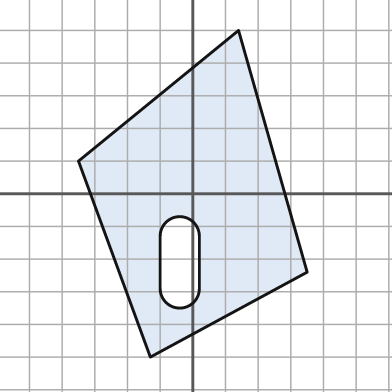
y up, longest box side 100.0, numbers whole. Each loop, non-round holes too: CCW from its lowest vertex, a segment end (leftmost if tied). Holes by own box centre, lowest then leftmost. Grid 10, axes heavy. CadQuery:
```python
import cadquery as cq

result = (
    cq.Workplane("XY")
    .moveTo(-13.0, -50.0)
    .lineTo(35.0, -24.0)
    .lineTo(14.0, 50.0)
    .lineTo(-35.0, 10.0)
    .close()
    .moveTo(-10.0, -29.0)
    .threePointArc((-4.0, -35.0), (2.0, -29.0))
    .lineTo(2.0, -13.0)
    .threePointArc((-4.0, -7.0), (-10.0, -13.0))
    .close()
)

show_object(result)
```